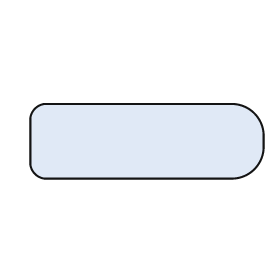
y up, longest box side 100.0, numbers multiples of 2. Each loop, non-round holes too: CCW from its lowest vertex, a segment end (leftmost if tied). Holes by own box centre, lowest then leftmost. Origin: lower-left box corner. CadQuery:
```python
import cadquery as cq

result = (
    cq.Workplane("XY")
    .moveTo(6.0, 0.0)
    .lineTo(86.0, 0.0)
    .threePointArc((96.0, 4.0), (100.0, 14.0))
    .lineTo(100.0, 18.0)
    .threePointArc((96.0, 28.0), (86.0, 32.0))
    .lineTo(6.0, 32.0)
    .threePointArc((2.0, 30.0), (0.0, 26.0))
    .lineTo(0.0, 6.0)
    .threePointArc((2.0, 2.0), (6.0, 0.0))
    .close()
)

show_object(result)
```